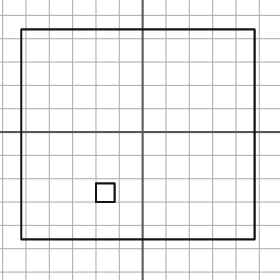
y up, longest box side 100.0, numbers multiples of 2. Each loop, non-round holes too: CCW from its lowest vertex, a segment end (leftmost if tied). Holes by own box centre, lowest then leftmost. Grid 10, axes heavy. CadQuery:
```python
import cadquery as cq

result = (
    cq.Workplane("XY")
    .moveTo(-52.0, -46.0)
    .lineTo(48.0, -46.0)
    .lineTo(48.0, 44.0)
    .lineTo(-52.0, 44.0)
    .close()
    .moveTo(-20.0, -30.0)
    .lineTo(-12.0, -30.0)
    .lineTo(-12.0, -22.0)
    .lineTo(-20.0, -22.0)
    .close()
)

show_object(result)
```